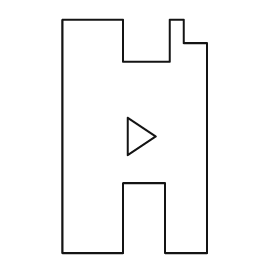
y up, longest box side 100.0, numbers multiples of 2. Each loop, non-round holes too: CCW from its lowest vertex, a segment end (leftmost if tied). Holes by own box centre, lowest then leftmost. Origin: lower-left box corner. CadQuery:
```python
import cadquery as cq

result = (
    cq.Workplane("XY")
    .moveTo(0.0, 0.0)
    .lineTo(26.0, 0.0)
    .lineTo(26.0, 30.0)
    .lineTo(44.0, 30.0)
    .lineTo(44.0, 0.0)
    .lineTo(62.0, 0.0)
    .lineTo(62.0, 90.0)
    .lineTo(52.0, 90.0)
    .lineTo(52.0, 100.0)
    .lineTo(46.0, 100.0)
    .lineTo(46.0, 82.0)
    .lineTo(26.0, 82.0)
    .lineTo(26.0, 100.0)
    .lineTo(0.0, 100.0)
    .close()
    .moveTo(28.0, 42.0)
    .lineTo(40.0, 50.0)
    .lineTo(28.0, 58.0)
    .close()
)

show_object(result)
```